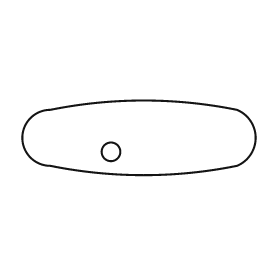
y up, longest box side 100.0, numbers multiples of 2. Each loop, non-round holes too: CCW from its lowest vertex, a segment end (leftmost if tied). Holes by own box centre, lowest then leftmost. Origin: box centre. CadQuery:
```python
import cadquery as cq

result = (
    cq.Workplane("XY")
    .moveTo(-38.0, -12.0)
    .threePointArc((2.0, -16.0), (42.0, -12.0))
    .threePointArc((50.0, 0.0), (42.0, 12.0))
    .threePointArc((2.0, 16.0), (-38.0, 12.0))
    .threePointArc((-50.0, 0.0), (-38.0, -12.0))
    .close()
    .moveTo(-12.0, -6.0)
    .circle(4.0)
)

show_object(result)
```